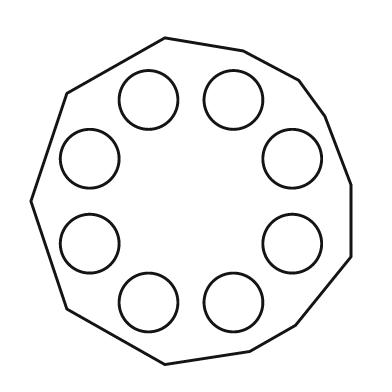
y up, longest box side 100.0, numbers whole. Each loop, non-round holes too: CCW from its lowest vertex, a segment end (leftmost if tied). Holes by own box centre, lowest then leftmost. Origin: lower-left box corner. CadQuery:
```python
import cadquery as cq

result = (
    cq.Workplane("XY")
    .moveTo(41.0, 0.0)
    .lineTo(67.0, 4.0)
    .lineTo(81.0, 12.0)
    .lineTo(98.0, 33.0)
    .lineTo(98.0, 55.0)
    .lineTo(90.0, 76.0)
    .lineTo(82.0, 87.0)
    .lineTo(65.0, 96.0)
    .lineTo(41.0, 100.0)
    .lineTo(11.0, 83.0)
    .lineTo(0.0, 50.0)
    .lineTo(11.0, 17.0)
    .close()
    .moveTo(36.0, 19.0)
    .circle(9.0)
    .moveTo(62.0, 19.0)
    .circle(9.0)
    .moveTo(18.0, 37.0)
    .circle(9.0)
    .moveTo(80.0, 37.0)
    .circle(9.0)
    .moveTo(18.0, 63.0)
    .circle(9.0)
    .moveTo(80.0, 63.0)
    .circle(9.0)
    .moveTo(36.0, 81.0)
    .circle(9.0)
    .moveTo(62.0, 81.0)
    .circle(9.0)
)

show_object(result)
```